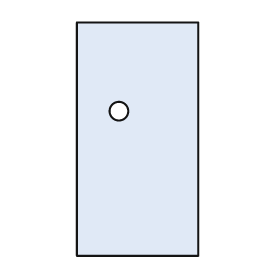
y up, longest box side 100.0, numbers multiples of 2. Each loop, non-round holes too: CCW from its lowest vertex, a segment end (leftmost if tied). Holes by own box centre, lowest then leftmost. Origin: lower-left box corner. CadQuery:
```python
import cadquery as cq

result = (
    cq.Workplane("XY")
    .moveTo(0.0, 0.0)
    .lineTo(52.0, 0.0)
    .lineTo(52.0, 100.0)
    .lineTo(0.0, 100.0)
    .close()
    .moveTo(18.0, 62.0)
    .circle(4.0)
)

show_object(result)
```